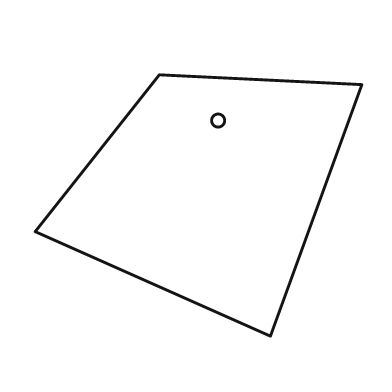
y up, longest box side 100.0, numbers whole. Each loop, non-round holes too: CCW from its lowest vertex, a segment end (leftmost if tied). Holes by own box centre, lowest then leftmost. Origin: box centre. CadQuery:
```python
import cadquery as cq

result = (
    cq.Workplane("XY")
    .moveTo(22.0, -40.0)
    .lineTo(50.0, 37.0)
    .lineTo(-12.0, 40.0)
    .lineTo(-50.0, -8.0)
    .close()
    .moveTo(6.0, 26.0)
    .circle(2.0)
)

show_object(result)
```